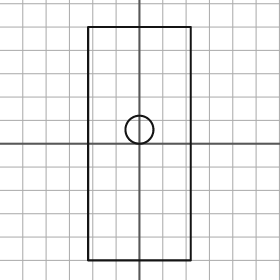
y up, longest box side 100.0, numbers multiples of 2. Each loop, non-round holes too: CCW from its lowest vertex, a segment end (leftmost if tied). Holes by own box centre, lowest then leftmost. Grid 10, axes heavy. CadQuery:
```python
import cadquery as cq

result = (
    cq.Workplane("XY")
    .moveTo(-22.0, -50.0)
    .lineTo(22.0, -50.0)
    .lineTo(22.0, 50.0)
    .lineTo(-22.0, 50.0)
    .close()
    .moveTo(0.0, 6.0)
    .circle(6.0)
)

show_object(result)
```